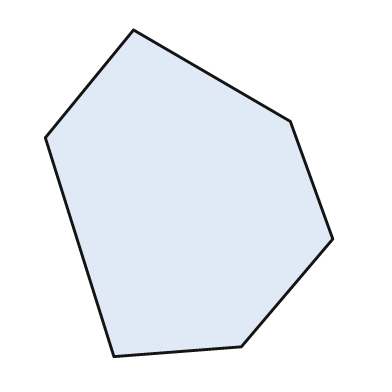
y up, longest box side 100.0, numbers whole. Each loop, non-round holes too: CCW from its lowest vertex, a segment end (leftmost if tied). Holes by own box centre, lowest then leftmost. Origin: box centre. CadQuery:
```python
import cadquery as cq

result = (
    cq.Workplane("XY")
    .moveTo(-23.0, -50.0)
    .lineTo(16.0, -47.0)
    .lineTo(44.0, -14.0)
    .lineTo(31.0, 22.0)
    .lineTo(-17.0, 50.0)
    .lineTo(-44.0, 17.0)
    .close()
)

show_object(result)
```